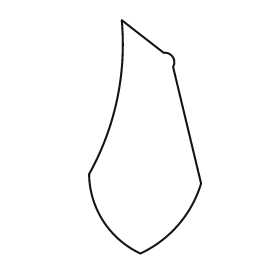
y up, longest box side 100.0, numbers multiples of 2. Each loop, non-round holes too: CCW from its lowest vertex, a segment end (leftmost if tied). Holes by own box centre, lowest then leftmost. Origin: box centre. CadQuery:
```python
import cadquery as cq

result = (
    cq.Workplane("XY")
    .moveTo(-2.0, -50.0)
    .threePointArc((14.0, -38.0), (24.0, -20.0))
    .lineTo(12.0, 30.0)
    .threePointArc((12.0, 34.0), (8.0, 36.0))
    .lineTo(-10.0, 50.0)
    .threePointArc((-12.0, 16.0), (-24.0, -16.0))
    .threePointArc((-18.0, -36.0), (-2.0, -50.0))
    .close()
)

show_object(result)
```